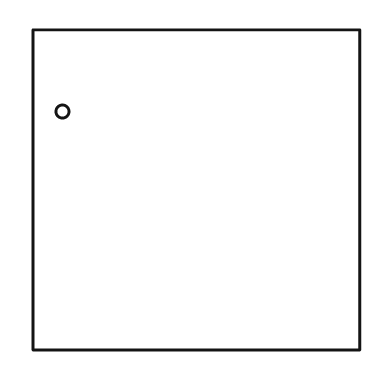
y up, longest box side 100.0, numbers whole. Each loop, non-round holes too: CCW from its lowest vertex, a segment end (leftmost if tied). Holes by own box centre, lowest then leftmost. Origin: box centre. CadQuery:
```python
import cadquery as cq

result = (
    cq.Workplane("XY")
    .moveTo(-50.0, -49.0)
    .lineTo(50.0, -49.0)
    .lineTo(50.0, 49.0)
    .lineTo(-50.0, 49.0)
    .close()
    .moveTo(-41.0, 24.0)
    .circle(2.0)
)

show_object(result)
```